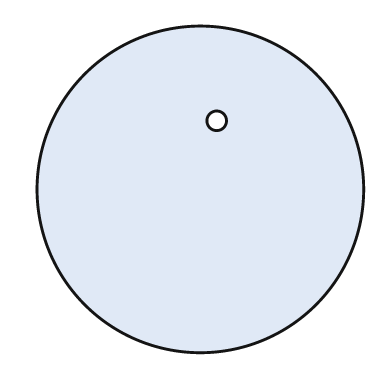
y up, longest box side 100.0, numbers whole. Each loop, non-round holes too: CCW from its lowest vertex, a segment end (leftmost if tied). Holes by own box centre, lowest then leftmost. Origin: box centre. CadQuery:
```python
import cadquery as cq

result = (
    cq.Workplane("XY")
    .moveTo(0.0, 0.0)
    .circle(50.0)
    .moveTo(5.0, 21.0)
    .circle(3.0)
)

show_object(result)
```